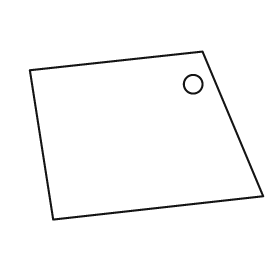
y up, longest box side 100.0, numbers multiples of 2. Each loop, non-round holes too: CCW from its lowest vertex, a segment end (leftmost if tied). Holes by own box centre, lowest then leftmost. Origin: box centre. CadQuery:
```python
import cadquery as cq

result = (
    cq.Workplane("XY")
    .moveTo(-40.0, -36.0)
    .lineTo(50.0, -26.0)
    .lineTo(24.0, 36.0)
    .lineTo(-50.0, 28.0)
    .close()
    .moveTo(20.0, 22.0)
    .circle(4.0)
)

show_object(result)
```